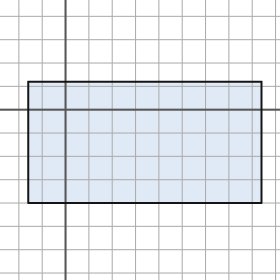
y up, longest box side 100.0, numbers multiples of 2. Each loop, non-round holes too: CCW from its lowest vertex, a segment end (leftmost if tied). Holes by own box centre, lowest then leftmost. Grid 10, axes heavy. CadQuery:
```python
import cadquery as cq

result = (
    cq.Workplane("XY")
    .moveTo(-16.0, -40.0)
    .lineTo(84.0, -40.0)
    .lineTo(84.0, 12.0)
    .lineTo(-16.0, 12.0)
    .close()
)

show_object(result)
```